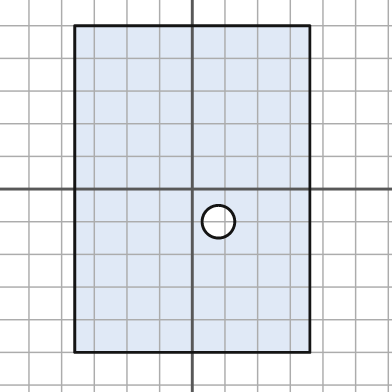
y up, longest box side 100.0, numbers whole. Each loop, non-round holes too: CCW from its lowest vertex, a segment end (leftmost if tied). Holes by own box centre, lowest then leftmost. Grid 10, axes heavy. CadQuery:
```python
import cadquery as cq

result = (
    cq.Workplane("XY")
    .moveTo(-36.0, -50.0)
    .lineTo(36.0, -50.0)
    .lineTo(36.0, 50.0)
    .lineTo(-36.0, 50.0)
    .close()
    .moveTo(8.0, -10.0)
    .circle(5.0)
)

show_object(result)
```